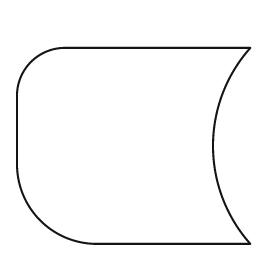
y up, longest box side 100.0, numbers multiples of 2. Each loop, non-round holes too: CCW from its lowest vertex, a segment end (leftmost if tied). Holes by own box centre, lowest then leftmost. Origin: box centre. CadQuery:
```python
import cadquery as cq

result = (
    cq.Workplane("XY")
    .moveTo(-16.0, -42.0)
    .lineTo(50.0, -42.0)
    .threePointArc((34.0, 0.0), (50.0, 42.0))
    .lineTo(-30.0, 42.0)
    .threePointArc((-44.0, 36.0), (-50.0, 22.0))
    .lineTo(-50.0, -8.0)
    .threePointArc((-40.0, -32.0), (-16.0, -42.0))
    .close()
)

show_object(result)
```